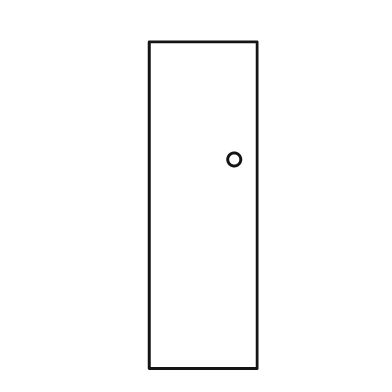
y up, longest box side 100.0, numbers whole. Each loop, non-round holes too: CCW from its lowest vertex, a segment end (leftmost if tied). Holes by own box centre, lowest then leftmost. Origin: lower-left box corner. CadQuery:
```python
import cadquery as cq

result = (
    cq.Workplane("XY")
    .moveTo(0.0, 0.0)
    .lineTo(33.0, 0.0)
    .lineTo(33.0, 100.0)
    .lineTo(0.0, 100.0)
    .close()
    .moveTo(26.0, 64.0)
    .circle(2.0)
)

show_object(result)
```